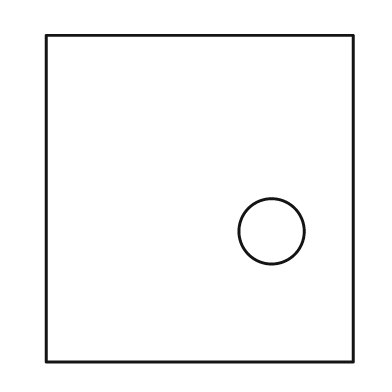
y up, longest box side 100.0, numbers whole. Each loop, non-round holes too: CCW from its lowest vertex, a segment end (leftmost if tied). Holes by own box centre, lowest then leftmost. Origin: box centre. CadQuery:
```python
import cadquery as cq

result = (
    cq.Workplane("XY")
    .moveTo(-47.0, -50.0)
    .lineTo(47.0, -50.0)
    .lineTo(47.0, 50.0)
    .lineTo(-47.0, 50.0)
    .close()
    .moveTo(22.0, -10.0)
    .circle(10.0)
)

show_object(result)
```